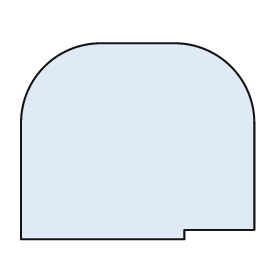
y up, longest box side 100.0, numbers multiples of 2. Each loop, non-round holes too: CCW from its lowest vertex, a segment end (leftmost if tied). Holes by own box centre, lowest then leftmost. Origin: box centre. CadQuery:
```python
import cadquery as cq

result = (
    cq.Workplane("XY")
    .moveTo(-50.0, -42.0)
    .lineTo(20.0, -42.0)
    .lineTo(20.0, -38.0)
    .lineTo(50.0, -38.0)
    .lineTo(50.0, 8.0)
    .threePointArc((40.0, 32.0), (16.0, 42.0))
    .lineTo(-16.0, 42.0)
    .threePointArc((-40.0, 32.0), (-50.0, 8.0))
    .close()
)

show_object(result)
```